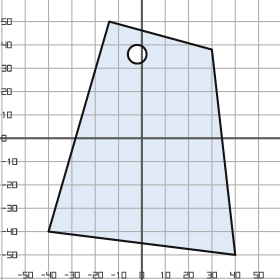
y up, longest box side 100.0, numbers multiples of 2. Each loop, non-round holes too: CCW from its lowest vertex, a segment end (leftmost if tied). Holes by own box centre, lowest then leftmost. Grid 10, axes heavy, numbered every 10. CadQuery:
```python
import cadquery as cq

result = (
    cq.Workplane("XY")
    .moveTo(40.0, -50.0)
    .lineTo(30.0, 38.0)
    .lineTo(-14.0, 50.0)
    .lineTo(-40.0, -40.0)
    .close()
    .moveTo(-2.0, 36.0)
    .circle(4.0)
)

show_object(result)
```